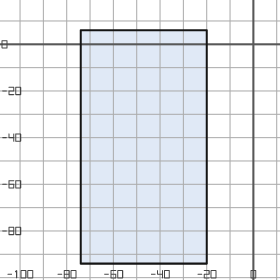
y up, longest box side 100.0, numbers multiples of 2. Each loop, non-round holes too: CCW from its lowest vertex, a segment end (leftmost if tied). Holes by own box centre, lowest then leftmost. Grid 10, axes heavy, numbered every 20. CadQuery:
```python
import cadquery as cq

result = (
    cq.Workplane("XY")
    .moveTo(-74.0, -94.0)
    .lineTo(-20.0, -94.0)
    .lineTo(-20.0, 6.0)
    .lineTo(-74.0, 6.0)
    .close()
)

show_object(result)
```